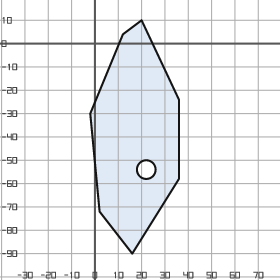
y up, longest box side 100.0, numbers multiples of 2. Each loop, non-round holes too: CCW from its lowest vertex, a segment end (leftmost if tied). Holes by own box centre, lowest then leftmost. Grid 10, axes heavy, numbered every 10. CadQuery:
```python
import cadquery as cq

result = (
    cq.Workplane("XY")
    .moveTo(16.0, -90.0)
    .lineTo(36.0, -58.0)
    .lineTo(36.0, -24.0)
    .lineTo(20.0, 10.0)
    .lineTo(12.0, 4.0)
    .lineTo(-2.0, -30.0)
    .lineTo(2.0, -72.0)
    .close()
    .moveTo(22.0, -54.0)
    .circle(4.0)
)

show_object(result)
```